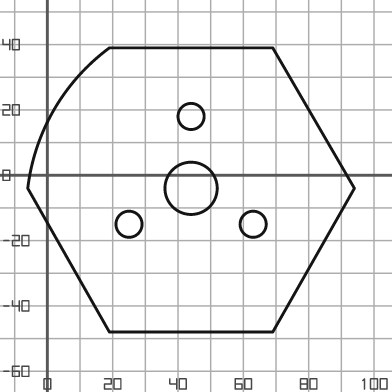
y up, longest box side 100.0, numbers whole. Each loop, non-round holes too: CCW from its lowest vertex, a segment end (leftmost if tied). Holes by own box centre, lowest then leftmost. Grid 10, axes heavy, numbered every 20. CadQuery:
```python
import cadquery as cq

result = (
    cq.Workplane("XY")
    .moveTo(19.0, -48.0)
    .lineTo(69.0, -48.0)
    .lineTo(94.0, -4.0)
    .lineTo(69.0, 39.0)
    .lineTo(19.0, 39.0)
    .threePointArc((2.0, 20.0), (-6.0, -4.0))
    .close()
    .moveTo(25.0, -15.0)
    .circle(4.0)
    .moveTo(63.0, -15.0)
    .circle(4.0)
    .moveTo(44.0, -4.0)
    .circle(8.0)
    .moveTo(44.0, 18.0)
    .circle(4.0)
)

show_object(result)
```